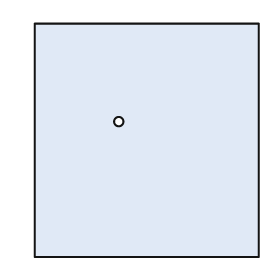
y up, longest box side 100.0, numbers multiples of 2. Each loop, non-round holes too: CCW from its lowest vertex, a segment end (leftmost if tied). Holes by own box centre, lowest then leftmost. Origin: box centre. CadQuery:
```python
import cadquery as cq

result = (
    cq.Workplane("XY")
    .moveTo(-48.0, -50.0)
    .lineTo(48.0, -50.0)
    .lineTo(48.0, 50.0)
    .lineTo(-48.0, 50.0)
    .close()
    .moveTo(-12.0, 8.0)
    .circle(2.0)
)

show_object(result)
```